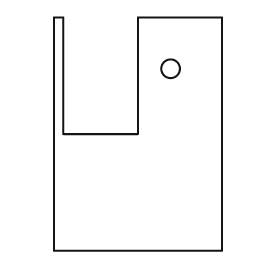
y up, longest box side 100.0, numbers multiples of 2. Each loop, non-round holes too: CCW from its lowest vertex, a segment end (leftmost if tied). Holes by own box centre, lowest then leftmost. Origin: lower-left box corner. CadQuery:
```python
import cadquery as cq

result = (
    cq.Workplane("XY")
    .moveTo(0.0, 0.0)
    .lineTo(72.0, 0.0)
    .lineTo(72.0, 100.0)
    .lineTo(36.0, 100.0)
    .lineTo(36.0, 50.0)
    .lineTo(4.0, 50.0)
    .lineTo(4.0, 100.0)
    .lineTo(0.0, 100.0)
    .close()
    .moveTo(50.0, 78.0)
    .circle(4.0)
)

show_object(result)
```